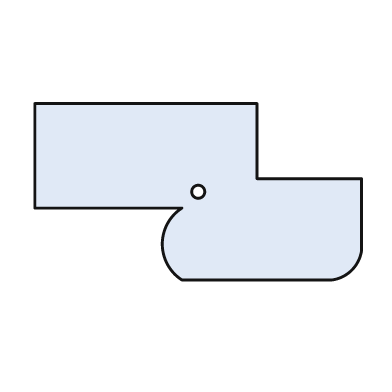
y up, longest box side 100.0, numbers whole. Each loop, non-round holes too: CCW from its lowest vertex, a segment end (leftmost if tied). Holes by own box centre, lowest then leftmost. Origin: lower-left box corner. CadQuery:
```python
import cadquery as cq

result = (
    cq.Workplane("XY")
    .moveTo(45.0, 0.0)
    .lineTo(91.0, 0.0)
    .threePointArc((97.0, 3.0), (100.0, 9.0))
    .lineTo(100.0, 31.0)
    .lineTo(68.0, 31.0)
    .lineTo(68.0, 54.0)
    .lineTo(0.0, 54.0)
    .lineTo(0.0, 22.0)
    .lineTo(45.0, 22.0)
    .threePointArc((39.0, 11.0), (45.0, 0.0))
    .close()
    .moveTo(50.0, 27.0)
    .circle(2.0)
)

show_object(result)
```